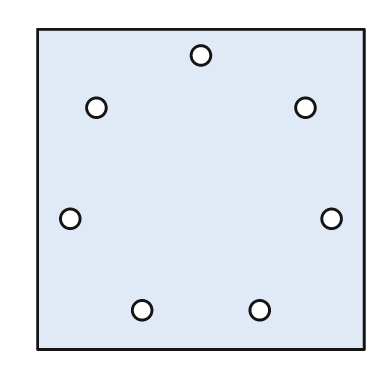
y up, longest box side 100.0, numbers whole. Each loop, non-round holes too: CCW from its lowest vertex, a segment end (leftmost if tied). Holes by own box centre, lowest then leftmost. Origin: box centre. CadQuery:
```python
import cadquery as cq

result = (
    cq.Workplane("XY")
    .moveTo(-50.0, -49.0)
    .lineTo(50.0, -49.0)
    .lineTo(50.0, 49.0)
    .lineTo(-50.0, 49.0)
    .close()
    .moveTo(-18.0, -37.0)
    .circle(3.0)
    .moveTo(18.0, -37.0)
    .circle(3.0)
    .moveTo(-40.0, -9.0)
    .circle(3.0)
    .moveTo(40.0, -9.0)
    .circle(3.0)
    .moveTo(-32.0, 25.0)
    .circle(3.0)
    .moveTo(32.0, 25.0)
    .circle(3.0)
    .moveTo(0.0, 41.0)
    .circle(3.0)
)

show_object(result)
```